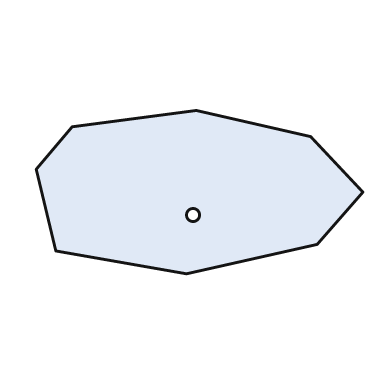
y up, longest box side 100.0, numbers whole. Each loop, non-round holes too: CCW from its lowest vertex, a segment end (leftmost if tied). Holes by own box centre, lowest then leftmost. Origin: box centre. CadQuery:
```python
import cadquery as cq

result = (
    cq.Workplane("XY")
    .moveTo(-4.0, -25.0)
    .lineTo(36.0, -16.0)
    .lineTo(50.0, 0.0)
    .lineTo(34.0, 17.0)
    .lineTo(-1.0, 25.0)
    .lineTo(-39.0, 20.0)
    .lineTo(-50.0, 7.0)
    .lineTo(-44.0, -18.0)
    .close()
    .moveTo(-2.0, -7.0)
    .circle(2.0)
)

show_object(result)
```